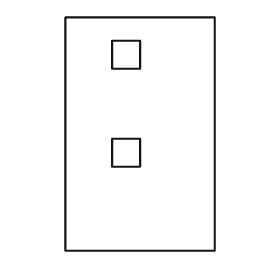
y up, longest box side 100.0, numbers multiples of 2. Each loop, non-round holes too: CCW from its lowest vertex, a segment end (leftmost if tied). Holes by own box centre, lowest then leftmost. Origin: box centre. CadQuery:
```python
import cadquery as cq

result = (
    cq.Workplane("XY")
    .moveTo(-32.0, -50.0)
    .lineTo(32.0, -50.0)
    .lineTo(32.0, 50.0)
    .lineTo(-32.0, 50.0)
    .close()
    .moveTo(-12.0, -14.0)
    .lineTo(0.0, -14.0)
    .lineTo(0.0, -2.0)
    .lineTo(-12.0, -2.0)
    .close()
    .moveTo(-12.0, 28.0)
    .lineTo(0.0, 28.0)
    .lineTo(0.0, 40.0)
    .lineTo(-12.0, 40.0)
    .close()
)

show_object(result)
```